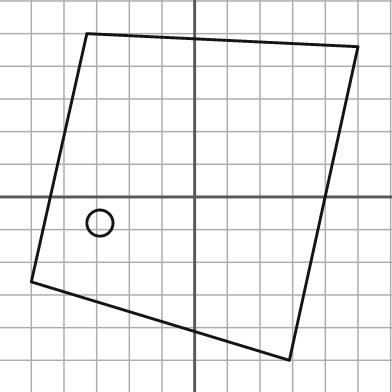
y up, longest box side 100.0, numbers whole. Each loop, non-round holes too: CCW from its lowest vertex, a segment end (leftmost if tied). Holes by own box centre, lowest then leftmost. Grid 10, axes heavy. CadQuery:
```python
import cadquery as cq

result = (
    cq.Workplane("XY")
    .moveTo(29.0, -50.0)
    .lineTo(50.0, 46.0)
    .lineTo(-33.0, 50.0)
    .lineTo(-50.0, -26.0)
    .close()
    .moveTo(-29.0, -8.0)
    .circle(4.0)
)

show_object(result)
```